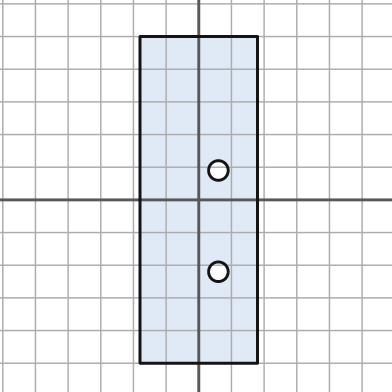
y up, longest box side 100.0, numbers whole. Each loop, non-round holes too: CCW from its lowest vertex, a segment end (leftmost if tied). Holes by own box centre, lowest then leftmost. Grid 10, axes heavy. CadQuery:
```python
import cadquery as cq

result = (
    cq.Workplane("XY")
    .moveTo(-18.0, -50.0)
    .lineTo(18.0, -50.0)
    .lineTo(18.0, 50.0)
    .lineTo(-18.0, 50.0)
    .close()
    .moveTo(6.0, -22.0)
    .circle(3.0)
    .moveTo(6.0, 9.0)
    .circle(3.0)
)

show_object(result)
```